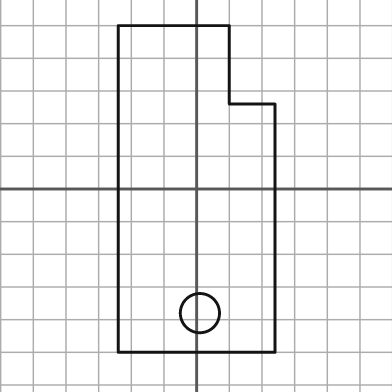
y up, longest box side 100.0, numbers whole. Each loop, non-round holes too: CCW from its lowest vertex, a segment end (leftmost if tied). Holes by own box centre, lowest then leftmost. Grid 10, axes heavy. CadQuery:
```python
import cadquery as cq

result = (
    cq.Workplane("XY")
    .moveTo(-24.0, -50.0)
    .lineTo(24.0, -50.0)
    .lineTo(24.0, 26.0)
    .lineTo(10.0, 26.0)
    .lineTo(10.0, 50.0)
    .lineTo(-24.0, 50.0)
    .close()
    .moveTo(1.0, -38.0)
    .circle(6.0)
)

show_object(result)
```